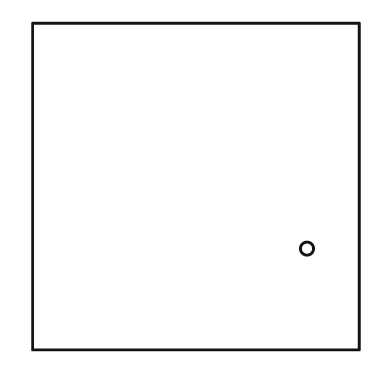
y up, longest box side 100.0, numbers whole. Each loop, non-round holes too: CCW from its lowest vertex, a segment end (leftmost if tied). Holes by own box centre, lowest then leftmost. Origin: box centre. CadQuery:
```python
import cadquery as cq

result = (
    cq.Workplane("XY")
    .moveTo(-50.0, -50.0)
    .lineTo(50.0, -50.0)
    .lineTo(50.0, 50.0)
    .lineTo(-50.0, 50.0)
    .close()
    .moveTo(34.0, -19.0)
    .circle(2.0)
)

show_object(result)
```